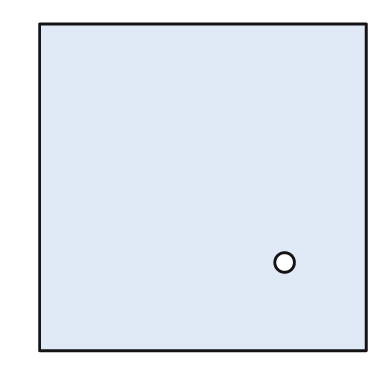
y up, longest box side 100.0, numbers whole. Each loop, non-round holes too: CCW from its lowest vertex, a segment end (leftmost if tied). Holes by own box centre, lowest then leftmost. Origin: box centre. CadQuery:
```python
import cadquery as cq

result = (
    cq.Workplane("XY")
    .moveTo(-50.0, -50.0)
    .lineTo(50.0, -50.0)
    .lineTo(50.0, 50.0)
    .lineTo(-50.0, 50.0)
    .close()
    .moveTo(25.0, -23.0)
    .circle(3.0)
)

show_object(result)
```